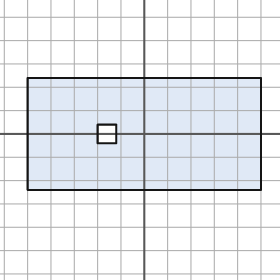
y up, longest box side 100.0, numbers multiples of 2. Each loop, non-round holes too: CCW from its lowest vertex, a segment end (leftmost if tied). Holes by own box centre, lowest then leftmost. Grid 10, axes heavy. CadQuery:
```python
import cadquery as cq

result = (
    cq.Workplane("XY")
    .moveTo(-50.0, -24.0)
    .lineTo(50.0, -24.0)
    .lineTo(50.0, 24.0)
    .lineTo(-50.0, 24.0)
    .close()
    .moveTo(-20.0, -4.0)
    .lineTo(-12.0, -4.0)
    .lineTo(-12.0, 4.0)
    .lineTo(-20.0, 4.0)
    .close()
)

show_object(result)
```